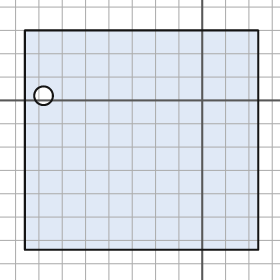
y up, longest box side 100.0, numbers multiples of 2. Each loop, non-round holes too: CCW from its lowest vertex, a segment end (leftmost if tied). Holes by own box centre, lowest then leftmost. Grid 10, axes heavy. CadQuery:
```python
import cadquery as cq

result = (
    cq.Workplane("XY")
    .moveTo(-76.0, -64.0)
    .lineTo(24.0, -64.0)
    .lineTo(24.0, 30.0)
    .lineTo(-76.0, 30.0)
    .close()
    .moveTo(-68.0, 2.0)
    .circle(4.0)
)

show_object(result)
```